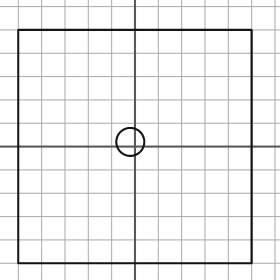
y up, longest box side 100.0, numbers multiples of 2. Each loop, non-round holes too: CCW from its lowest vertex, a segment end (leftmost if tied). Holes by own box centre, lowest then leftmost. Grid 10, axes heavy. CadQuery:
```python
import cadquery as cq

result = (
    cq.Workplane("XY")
    .moveTo(-50.0, -50.0)
    .lineTo(50.0, -50.0)
    .lineTo(50.0, 50.0)
    .lineTo(-50.0, 50.0)
    .close()
    .moveTo(-2.0, 2.0)
    .circle(6.0)
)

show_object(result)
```